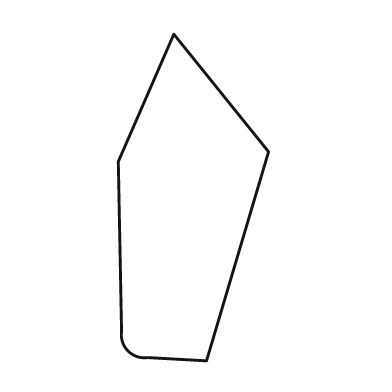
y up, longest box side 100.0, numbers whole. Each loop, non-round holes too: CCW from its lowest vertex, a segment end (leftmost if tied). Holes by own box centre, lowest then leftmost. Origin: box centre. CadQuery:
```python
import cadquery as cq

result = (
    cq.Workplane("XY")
    .moveTo(4.0, -50.0)
    .lineTo(23.0, 14.0)
    .lineTo(-6.0, 50.0)
    .lineTo(-23.0, 11.0)
    .lineTo(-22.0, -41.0)
    .threePointArc((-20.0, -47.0), (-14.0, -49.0))
    .close()
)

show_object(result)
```